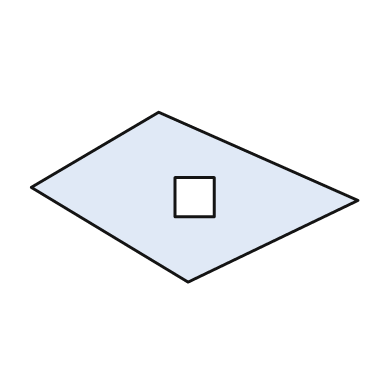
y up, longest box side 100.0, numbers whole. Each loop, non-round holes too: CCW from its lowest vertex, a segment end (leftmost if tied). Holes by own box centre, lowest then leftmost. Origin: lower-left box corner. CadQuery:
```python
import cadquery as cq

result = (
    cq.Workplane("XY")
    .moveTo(48.0, 0.0)
    .lineTo(100.0, 25.0)
    .lineTo(39.0, 52.0)
    .lineTo(0.0, 29.0)
    .close()
    .moveTo(44.0, 20.0)
    .lineTo(56.0, 20.0)
    .lineTo(56.0, 32.0)
    .lineTo(44.0, 32.0)
    .close()
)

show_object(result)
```